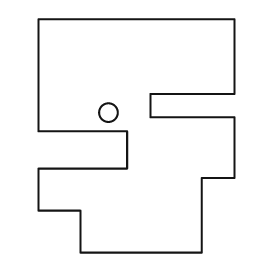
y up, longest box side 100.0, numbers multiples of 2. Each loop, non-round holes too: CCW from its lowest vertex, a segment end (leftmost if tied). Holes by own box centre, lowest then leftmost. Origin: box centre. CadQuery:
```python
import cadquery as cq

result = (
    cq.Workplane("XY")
    .moveTo(-24.0, -50.0)
    .lineTo(28.0, -50.0)
    .lineTo(28.0, -18.0)
    .lineTo(42.0, -18.0)
    .lineTo(42.0, 8.0)
    .lineTo(6.0, 8.0)
    .lineTo(6.0, 18.0)
    .lineTo(42.0, 18.0)
    .lineTo(42.0, 50.0)
    .lineTo(-42.0, 50.0)
    .lineTo(-42.0, 2.0)
    .lineTo(-4.0, 2.0)
    .lineTo(-4.0, -14.0)
    .lineTo(-42.0, -14.0)
    .lineTo(-42.0, -32.0)
    .lineTo(-24.0, -32.0)
    .close()
    .moveTo(-12.0, 10.0)
    .circle(4.0)
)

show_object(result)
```